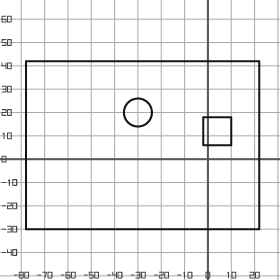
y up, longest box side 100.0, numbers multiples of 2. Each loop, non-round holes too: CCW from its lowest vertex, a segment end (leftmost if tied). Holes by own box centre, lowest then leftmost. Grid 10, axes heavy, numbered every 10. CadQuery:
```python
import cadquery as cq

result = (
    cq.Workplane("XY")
    .moveTo(-78.0, -30.0)
    .lineTo(22.0, -30.0)
    .lineTo(22.0, 42.0)
    .lineTo(-78.0, 42.0)
    .close()
    .moveTo(-2.0, 6.0)
    .lineTo(10.0, 6.0)
    .lineTo(10.0, 18.0)
    .lineTo(-2.0, 18.0)
    .close()
    .moveTo(-30.0, 20.0)
    .circle(6.0)
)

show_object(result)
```